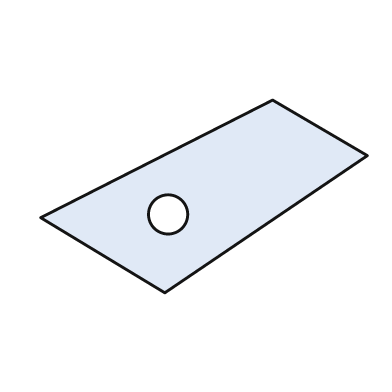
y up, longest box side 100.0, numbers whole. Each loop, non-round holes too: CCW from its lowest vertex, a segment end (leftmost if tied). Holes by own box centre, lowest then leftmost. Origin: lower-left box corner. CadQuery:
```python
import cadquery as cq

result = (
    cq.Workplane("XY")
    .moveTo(38.0, 0.0)
    .lineTo(100.0, 42.0)
    .lineTo(71.0, 59.0)
    .lineTo(0.0, 23.0)
    .close()
    .moveTo(39.0, 24.0)
    .circle(6.0)
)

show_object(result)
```